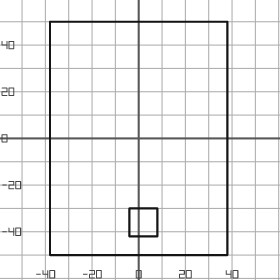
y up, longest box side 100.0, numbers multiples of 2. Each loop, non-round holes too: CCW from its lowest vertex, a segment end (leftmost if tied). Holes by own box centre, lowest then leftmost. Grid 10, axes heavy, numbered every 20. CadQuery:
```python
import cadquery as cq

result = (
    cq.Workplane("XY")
    .moveTo(-38.0, -50.0)
    .lineTo(38.0, -50.0)
    .lineTo(38.0, 50.0)
    .lineTo(-38.0, 50.0)
    .close()
    .moveTo(-4.0, -42.0)
    .lineTo(8.0, -42.0)
    .lineTo(8.0, -30.0)
    .lineTo(-4.0, -30.0)
    .close()
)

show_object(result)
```